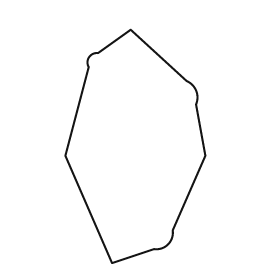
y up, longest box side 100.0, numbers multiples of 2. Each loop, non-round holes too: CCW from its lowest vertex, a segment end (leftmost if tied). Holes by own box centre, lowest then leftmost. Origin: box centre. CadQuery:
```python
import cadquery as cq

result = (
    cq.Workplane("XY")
    .moveTo(-10.0, -50.0)
    .lineTo(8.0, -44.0)
    .threePointArc((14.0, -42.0), (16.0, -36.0))
    .lineTo(30.0, -4.0)
    .lineTo(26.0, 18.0)
    .threePointArc((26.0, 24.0), (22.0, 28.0))
    .lineTo(-2.0, 50.0)
    .lineTo(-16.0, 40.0)
    .threePointArc((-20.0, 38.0), (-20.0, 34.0))
    .lineTo(-30.0, -4.0)
    .close()
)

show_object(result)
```